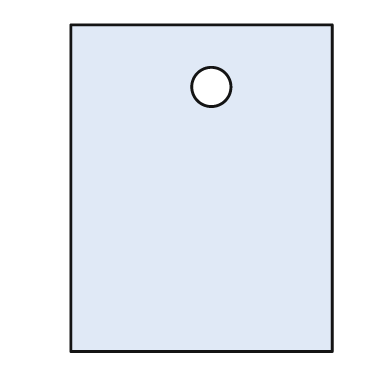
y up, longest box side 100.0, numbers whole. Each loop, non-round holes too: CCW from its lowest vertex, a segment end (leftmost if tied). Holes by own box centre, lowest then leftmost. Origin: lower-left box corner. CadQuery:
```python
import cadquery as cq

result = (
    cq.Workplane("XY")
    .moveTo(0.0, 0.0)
    .lineTo(80.0, 0.0)
    .lineTo(80.0, 100.0)
    .lineTo(0.0, 100.0)
    .close()
    .moveTo(43.0, 81.0)
    .circle(6.0)
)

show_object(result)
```